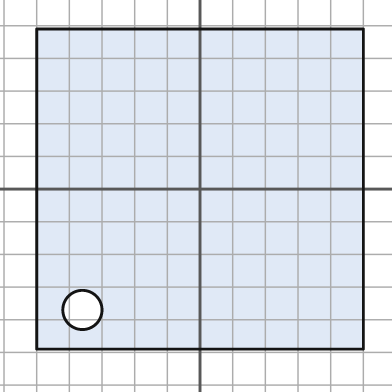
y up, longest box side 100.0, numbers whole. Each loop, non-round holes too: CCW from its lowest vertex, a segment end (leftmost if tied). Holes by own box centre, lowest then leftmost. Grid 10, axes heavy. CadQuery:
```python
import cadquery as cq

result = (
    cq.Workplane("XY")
    .moveTo(-50.0, -49.0)
    .lineTo(50.0, -49.0)
    .lineTo(50.0, 49.0)
    .lineTo(-50.0, 49.0)
    .close()
    .moveTo(-36.0, -37.0)
    .circle(6.0)
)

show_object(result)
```